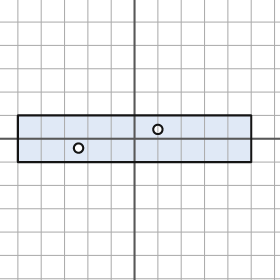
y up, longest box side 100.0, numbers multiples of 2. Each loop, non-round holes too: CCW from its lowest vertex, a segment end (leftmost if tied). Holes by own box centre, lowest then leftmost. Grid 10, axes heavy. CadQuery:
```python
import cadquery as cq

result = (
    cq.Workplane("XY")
    .moveTo(-50.0, -10.0)
    .lineTo(50.0, -10.0)
    .lineTo(50.0, 10.0)
    .lineTo(-50.0, 10.0)
    .close()
    .moveTo(-24.0, -4.0)
    .circle(2.0)
    .moveTo(10.0, 4.0)
    .circle(2.0)
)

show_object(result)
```